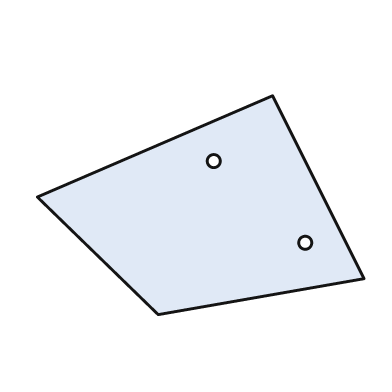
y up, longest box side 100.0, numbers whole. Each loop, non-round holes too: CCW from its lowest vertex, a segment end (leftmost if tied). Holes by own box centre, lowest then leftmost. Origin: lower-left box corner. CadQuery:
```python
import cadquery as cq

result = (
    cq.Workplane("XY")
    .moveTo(37.0, 0.0)
    .lineTo(100.0, 11.0)
    .lineTo(72.0, 67.0)
    .lineTo(0.0, 36.0)
    .close()
    .moveTo(82.0, 22.0)
    .circle(2.0)
    .moveTo(54.0, 47.0)
    .circle(2.0)
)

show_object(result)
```